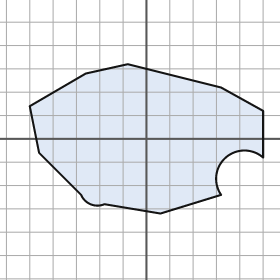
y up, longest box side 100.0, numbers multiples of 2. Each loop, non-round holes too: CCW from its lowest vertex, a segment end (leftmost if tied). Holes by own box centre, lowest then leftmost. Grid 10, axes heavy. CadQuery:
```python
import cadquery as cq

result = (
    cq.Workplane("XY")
    .moveTo(6.0, -32.0)
    .lineTo(32.0, -24.0)
    .threePointArc((34.0, -8.0), (50.0, -8.0))
    .lineTo(50.0, 12.0)
    .lineTo(32.0, 22.0)
    .lineTo(-8.0, 32.0)
    .lineTo(-26.0, 28.0)
    .lineTo(-50.0, 14.0)
    .lineTo(-46.0, -6.0)
    .lineTo(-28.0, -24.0)
    .threePointArc((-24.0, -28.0), (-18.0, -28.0))
    .close()
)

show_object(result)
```